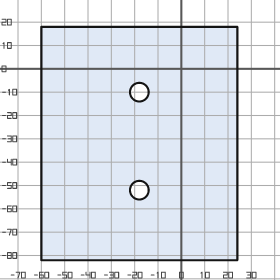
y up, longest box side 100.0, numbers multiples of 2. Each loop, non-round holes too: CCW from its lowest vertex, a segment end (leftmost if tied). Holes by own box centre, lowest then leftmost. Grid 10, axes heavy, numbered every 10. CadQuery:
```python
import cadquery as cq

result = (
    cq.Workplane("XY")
    .moveTo(-60.0, -82.0)
    .lineTo(24.0, -82.0)
    .lineTo(24.0, 18.0)
    .lineTo(-60.0, 18.0)
    .close()
    .moveTo(-18.0, -52.0)
    .circle(4.0)
    .moveTo(-18.0, -10.0)
    .circle(4.0)
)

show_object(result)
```